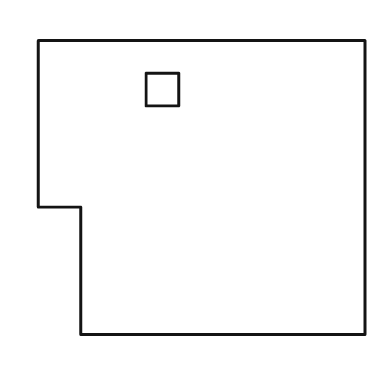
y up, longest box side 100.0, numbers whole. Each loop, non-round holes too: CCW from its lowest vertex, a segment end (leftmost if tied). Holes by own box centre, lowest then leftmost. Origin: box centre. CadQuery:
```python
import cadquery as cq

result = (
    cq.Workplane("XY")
    .moveTo(-37.0, -45.0)
    .lineTo(50.0, -45.0)
    .lineTo(50.0, 45.0)
    .lineTo(-50.0, 45.0)
    .lineTo(-50.0, -6.0)
    .lineTo(-37.0, -6.0)
    .close()
    .moveTo(-17.0, 25.0)
    .lineTo(-7.0, 25.0)
    .lineTo(-7.0, 35.0)
    .lineTo(-17.0, 35.0)
    .close()
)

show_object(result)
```